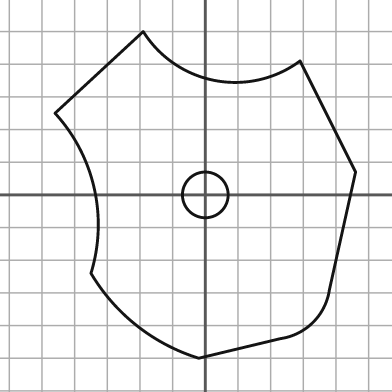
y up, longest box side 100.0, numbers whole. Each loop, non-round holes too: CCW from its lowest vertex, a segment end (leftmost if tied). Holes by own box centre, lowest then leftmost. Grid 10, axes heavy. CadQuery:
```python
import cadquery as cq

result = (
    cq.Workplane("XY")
    .moveTo(-2.0, -50.0)
    .lineTo(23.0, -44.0)
    .threePointArc((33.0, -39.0), (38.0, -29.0))
    .lineTo(46.0, 7.0)
    .lineTo(29.0, 41.0)
    .threePointArc((3.0, 35.0), (-19.0, 50.0))
    .lineTo(-46.0, 25.0)
    .threePointArc((-34.0, 2.0), (-35.0, -24.0))
    .threePointArc((-21.0, -40.0), (-2.0, -50.0))
    .close()
    .moveTo(0.0, 0.0)
    .circle(7.0)
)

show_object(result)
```